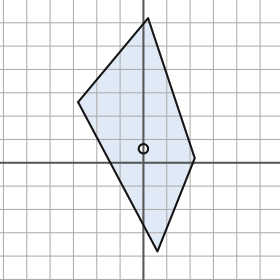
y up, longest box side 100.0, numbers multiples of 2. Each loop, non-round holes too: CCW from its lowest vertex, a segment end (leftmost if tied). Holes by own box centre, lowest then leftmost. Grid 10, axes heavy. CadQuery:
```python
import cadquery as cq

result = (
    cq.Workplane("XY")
    .moveTo(6.0, -38.0)
    .lineTo(22.0, 2.0)
    .lineTo(2.0, 62.0)
    .lineTo(-28.0, 26.0)
    .close()
    .moveTo(0.0, 6.0)
    .circle(2.0)
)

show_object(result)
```